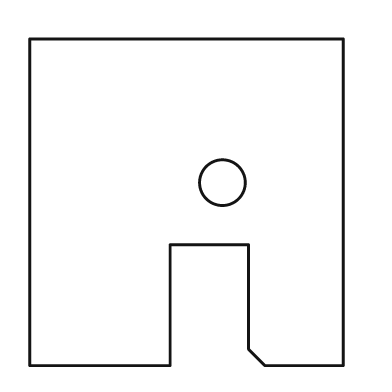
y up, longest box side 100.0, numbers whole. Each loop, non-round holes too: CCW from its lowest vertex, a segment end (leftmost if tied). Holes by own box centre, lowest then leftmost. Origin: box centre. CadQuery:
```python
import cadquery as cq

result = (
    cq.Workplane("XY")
    .moveTo(-48.0, -50.0)
    .lineTo(-5.0, -50.0)
    .lineTo(-5.0, -13.0)
    .lineTo(19.0, -13.0)
    .lineTo(19.0, -45.0)
    .lineTo(24.0, -50.0)
    .lineTo(48.0, -50.0)
    .lineTo(48.0, 50.0)
    .lineTo(-48.0, 50.0)
    .close()
    .moveTo(11.0, 6.0)
    .circle(7.0)
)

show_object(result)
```